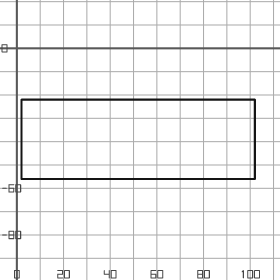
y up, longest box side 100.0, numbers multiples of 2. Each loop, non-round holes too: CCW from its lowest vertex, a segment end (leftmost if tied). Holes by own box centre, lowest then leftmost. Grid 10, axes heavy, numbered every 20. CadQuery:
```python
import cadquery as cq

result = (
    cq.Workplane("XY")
    .moveTo(2.0, -56.0)
    .lineTo(102.0, -56.0)
    .lineTo(102.0, -22.0)
    .lineTo(2.0, -22.0)
    .close()
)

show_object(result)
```